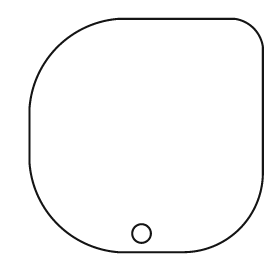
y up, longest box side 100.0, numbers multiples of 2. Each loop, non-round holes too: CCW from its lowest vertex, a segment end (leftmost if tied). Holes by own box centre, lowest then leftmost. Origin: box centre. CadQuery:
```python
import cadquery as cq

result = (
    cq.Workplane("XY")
    .moveTo(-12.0, -50.0)
    .lineTo(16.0, -50.0)
    .threePointArc((40.0, -40.0), (50.0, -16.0))
    .lineTo(50.0, 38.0)
    .threePointArc((46.0, 46.0), (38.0, 50.0))
    .lineTo(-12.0, 50.0)
    .threePointArc((-38.0, 38.0), (-50.0, 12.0))
    .lineTo(-50.0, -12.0)
    .threePointArc((-38.0, -38.0), (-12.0, -50.0))
    .close()
    .moveTo(-2.0, -42.0)
    .circle(4.0)
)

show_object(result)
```